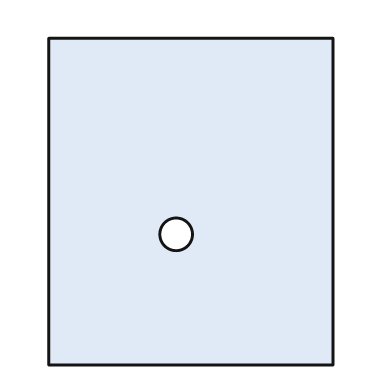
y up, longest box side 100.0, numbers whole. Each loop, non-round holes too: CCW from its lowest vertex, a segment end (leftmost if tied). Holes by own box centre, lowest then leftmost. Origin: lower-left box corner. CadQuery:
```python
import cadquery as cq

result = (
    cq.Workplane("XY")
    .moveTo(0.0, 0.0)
    .lineTo(87.0, 0.0)
    .lineTo(87.0, 100.0)
    .lineTo(0.0, 100.0)
    .close()
    .moveTo(39.0, 40.0)
    .circle(5.0)
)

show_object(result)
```